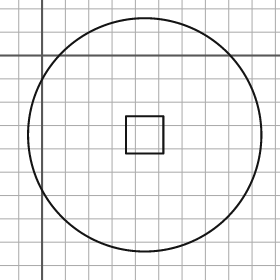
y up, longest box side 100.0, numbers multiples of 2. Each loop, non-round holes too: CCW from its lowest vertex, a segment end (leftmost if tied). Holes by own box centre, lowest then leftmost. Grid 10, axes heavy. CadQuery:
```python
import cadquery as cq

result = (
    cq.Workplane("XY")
    .moveTo(44.0, -34.0)
    .circle(50.0)
    .moveTo(36.0, -42.0)
    .lineTo(52.0, -42.0)
    .lineTo(52.0, -26.0)
    .lineTo(36.0, -26.0)
    .close()
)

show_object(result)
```